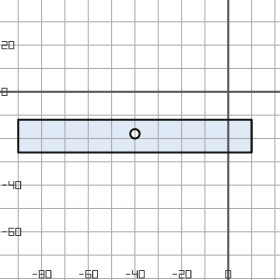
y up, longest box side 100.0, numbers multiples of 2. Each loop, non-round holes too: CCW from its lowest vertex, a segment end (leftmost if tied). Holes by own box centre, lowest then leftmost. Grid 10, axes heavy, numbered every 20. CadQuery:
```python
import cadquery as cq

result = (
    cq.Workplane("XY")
    .moveTo(-90.0, -26.0)
    .lineTo(10.0, -26.0)
    .lineTo(10.0, -12.0)
    .lineTo(-90.0, -12.0)
    .close()
    .moveTo(-40.0, -18.0)
    .circle(2.0)
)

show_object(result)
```